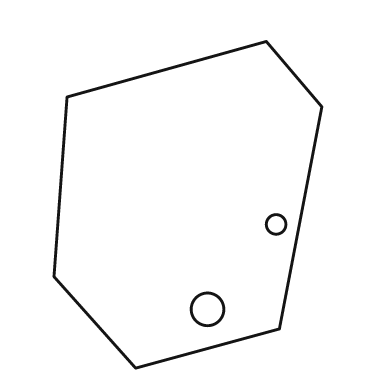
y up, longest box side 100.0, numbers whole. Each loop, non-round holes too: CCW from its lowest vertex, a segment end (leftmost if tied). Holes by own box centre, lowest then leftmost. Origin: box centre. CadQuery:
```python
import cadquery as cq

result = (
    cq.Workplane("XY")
    .moveTo(-16.0, -50.0)
    .lineTo(28.0, -38.0)
    .lineTo(41.0, 30.0)
    .lineTo(24.0, 50.0)
    .lineTo(-37.0, 33.0)
    .lineTo(-41.0, -22.0)
    .close()
    .moveTo(6.0, -32.0)
    .circle(5.0)
    .moveTo(27.0, -6.0)
    .circle(3.0)
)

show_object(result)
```